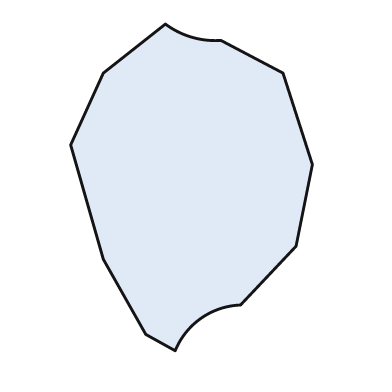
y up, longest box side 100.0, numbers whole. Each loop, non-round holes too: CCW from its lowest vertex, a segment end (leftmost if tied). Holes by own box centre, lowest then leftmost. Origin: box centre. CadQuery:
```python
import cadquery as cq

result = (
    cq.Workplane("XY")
    .moveTo(-5.0, -50.0)
    .threePointArc((3.0, -40.0), (15.0, -36.0))
    .lineTo(32.0, -18.0)
    .lineTo(37.0, 7.0)
    .lineTo(28.0, 35.0)
    .lineTo(9.0, 45.0)
    .threePointArc((0.0, 46.0), (-8.0, 50.0))
    .lineTo(-27.0, 35.0)
    .lineTo(-37.0, 13.0)
    .lineTo(-27.0, -22.0)
    .lineTo(-14.0, -45.0)
    .close()
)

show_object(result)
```